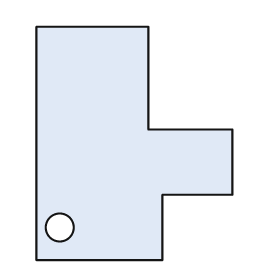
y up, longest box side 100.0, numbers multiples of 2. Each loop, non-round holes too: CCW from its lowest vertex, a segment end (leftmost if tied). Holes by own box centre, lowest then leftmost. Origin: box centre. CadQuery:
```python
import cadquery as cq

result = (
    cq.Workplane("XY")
    .moveTo(-42.0, -50.0)
    .lineTo(12.0, -50.0)
    .lineTo(12.0, -22.0)
    .lineTo(42.0, -22.0)
    .lineTo(42.0, 6.0)
    .lineTo(6.0, 6.0)
    .lineTo(6.0, 50.0)
    .lineTo(-42.0, 50.0)
    .close()
    .moveTo(-32.0, -36.0)
    .circle(6.0)
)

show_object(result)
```